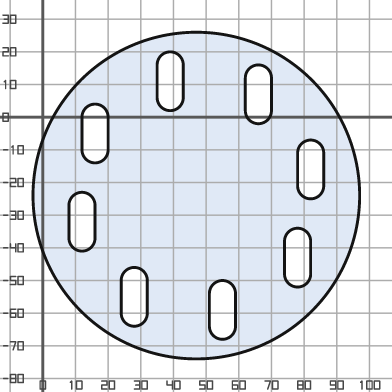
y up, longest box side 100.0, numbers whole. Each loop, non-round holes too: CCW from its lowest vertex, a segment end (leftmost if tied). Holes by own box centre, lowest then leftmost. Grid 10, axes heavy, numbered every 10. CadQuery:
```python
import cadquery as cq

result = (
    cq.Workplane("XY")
    .moveTo(47.0, -24.0)
    .circle(50.0)
    .moveTo(51.0, -64.0)
    .threePointArc((55.0, -68.0), (59.0, -64.0))
    .lineTo(59.0, -54.0)
    .threePointArc((55.0, -50.0), (51.0, -54.0))
    .close()
    .moveTo(24.0, -60.0)
    .threePointArc((28.0, -64.0), (32.0, -60.0))
    .lineTo(32.0, -50.0)
    .threePointArc((28.0, -46.0), (24.0, -50.0))
    .close()
    .moveTo(74.0, -48.0)
    .threePointArc((78.0, -52.0), (82.0, -48.0))
    .lineTo(82.0, -38.0)
    .threePointArc((78.0, -34.0), (74.0, -38.0))
    .close()
    .moveTo(8.0, -37.0)
    .threePointArc((12.0, -41.0), (16.0, -37.0))
    .lineTo(16.0, -27.0)
    .threePointArc((12.0, -23.0), (8.0, -27.0))
    .close()
    .moveTo(78.0, -21.0)
    .threePointArc((82.0, -25.0), (86.0, -21.0))
    .lineTo(86.0, -11.0)
    .threePointArc((82.0, -7.0), (78.0, -11.0))
    .close()
    .moveTo(12.0, -10.0)
    .threePointArc((16.0, -14.0), (20.0, -10.0))
    .lineTo(20.0, 0.0)
    .threePointArc((16.0, 4.0), (12.0, 0.0))
    .close()
    .moveTo(62.0, 2.0)
    .threePointArc((66.0, -2.0), (70.0, 2.0))
    .lineTo(70.0, 12.0)
    .threePointArc((66.0, 16.0), (62.0, 12.0))
    .close()
    .moveTo(35.0, 6.0)
    .threePointArc((39.0, 2.0), (43.0, 6.0))
    .lineTo(43.0, 16.0)
    .threePointArc((39.0, 20.0), (35.0, 16.0))
    .close()
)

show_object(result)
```